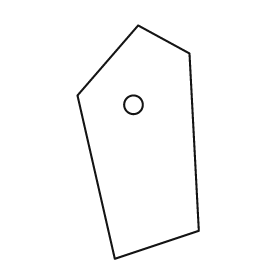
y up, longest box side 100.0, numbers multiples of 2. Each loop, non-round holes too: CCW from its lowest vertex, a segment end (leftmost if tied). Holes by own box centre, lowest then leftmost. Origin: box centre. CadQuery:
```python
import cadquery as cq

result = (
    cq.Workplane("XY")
    .moveTo(-10.0, -50.0)
    .lineTo(26.0, -38.0)
    .lineTo(22.0, 38.0)
    .lineTo(0.0, 50.0)
    .lineTo(-26.0, 20.0)
    .close()
    .moveTo(-2.0, 16.0)
    .circle(4.0)
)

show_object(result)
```